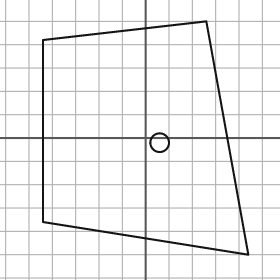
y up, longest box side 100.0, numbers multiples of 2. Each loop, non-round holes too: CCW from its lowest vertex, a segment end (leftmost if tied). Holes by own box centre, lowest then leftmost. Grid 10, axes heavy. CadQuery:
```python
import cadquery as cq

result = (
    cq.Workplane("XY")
    .moveTo(44.0, -50.0)
    .lineTo(26.0, 50.0)
    .lineTo(-44.0, 42.0)
    .lineTo(-44.0, -36.0)
    .close()
    .moveTo(6.0, -2.0)
    .circle(4.0)
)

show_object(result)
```